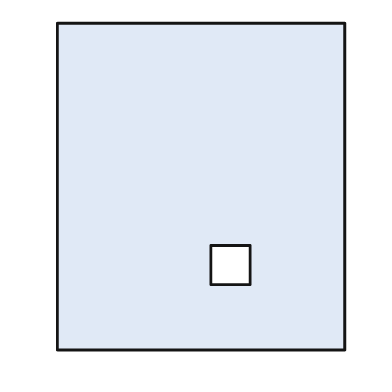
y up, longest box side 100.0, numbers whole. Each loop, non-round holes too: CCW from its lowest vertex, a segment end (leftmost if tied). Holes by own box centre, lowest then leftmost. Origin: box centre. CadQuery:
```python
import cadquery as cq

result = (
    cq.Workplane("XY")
    .moveTo(-44.0, -50.0)
    .lineTo(44.0, -50.0)
    .lineTo(44.0, 50.0)
    .lineTo(-44.0, 50.0)
    .close()
    .moveTo(3.0, -30.0)
    .lineTo(15.0, -30.0)
    .lineTo(15.0, -18.0)
    .lineTo(3.0, -18.0)
    .close()
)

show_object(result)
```